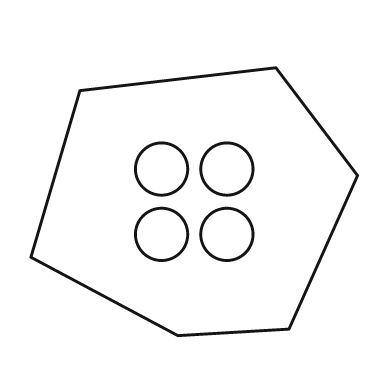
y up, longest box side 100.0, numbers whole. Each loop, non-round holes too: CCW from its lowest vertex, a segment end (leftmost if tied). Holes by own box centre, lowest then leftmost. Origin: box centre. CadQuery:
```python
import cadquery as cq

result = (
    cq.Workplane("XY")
    .moveTo(-5.0, -41.0)
    .lineTo(29.0, -39.0)
    .lineTo(50.0, 8.0)
    .lineTo(25.0, 41.0)
    .lineTo(-35.0, 34.0)
    .lineTo(-50.0, -17.0)
    .close()
    .moveTo(-10.0, -10.0)
    .circle(8.0)
    .moveTo(10.0, -10.0)
    .circle(8.0)
    .moveTo(-10.0, 10.0)
    .circle(8.0)
    .moveTo(10.0, 10.0)
    .circle(8.0)
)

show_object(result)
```